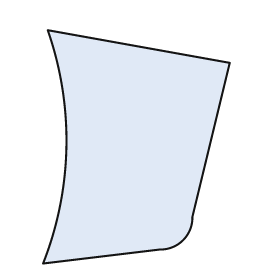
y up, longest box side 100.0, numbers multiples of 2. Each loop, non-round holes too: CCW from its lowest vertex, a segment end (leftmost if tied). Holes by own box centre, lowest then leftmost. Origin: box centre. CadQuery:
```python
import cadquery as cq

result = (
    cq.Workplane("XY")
    .moveTo(-40.0, -50.0)
    .lineTo(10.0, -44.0)
    .threePointArc((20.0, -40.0), (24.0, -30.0))
    .lineTo(40.0, 36.0)
    .lineTo(-38.0, 50.0)
    .threePointArc((-30.0, 0.0), (-40.0, -50.0))
    .close()
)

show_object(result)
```